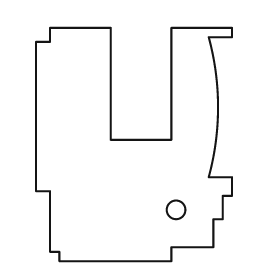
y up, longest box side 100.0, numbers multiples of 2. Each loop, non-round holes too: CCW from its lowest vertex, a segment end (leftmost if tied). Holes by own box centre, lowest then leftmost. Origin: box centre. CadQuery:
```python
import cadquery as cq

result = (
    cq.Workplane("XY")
    .moveTo(-32.0, -50.0)
    .lineTo(16.0, -50.0)
    .lineTo(16.0, -44.0)
    .lineTo(34.0, -44.0)
    .lineTo(34.0, -32.0)
    .lineTo(38.0, -32.0)
    .lineTo(38.0, -22.0)
    .lineTo(42.0, -22.0)
    .lineTo(42.0, -14.0)
    .lineTo(32.0, -14.0)
    .threePointArc((36.0, 16.0), (32.0, 46.0))
    .lineTo(42.0, 46.0)
    .lineTo(42.0, 50.0)
    .lineTo(16.0, 50.0)
    .lineTo(16.0, 2.0)
    .lineTo(-10.0, 2.0)
    .lineTo(-10.0, 50.0)
    .lineTo(-36.0, 50.0)
    .lineTo(-36.0, 44.0)
    .lineTo(-42.0, 44.0)
    .lineTo(-42.0, -20.0)
    .lineTo(-36.0, -20.0)
    .lineTo(-36.0, -46.0)
    .lineTo(-32.0, -46.0)
    .close()
    .moveTo(18.0, -28.0)
    .circle(4.0)
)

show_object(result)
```